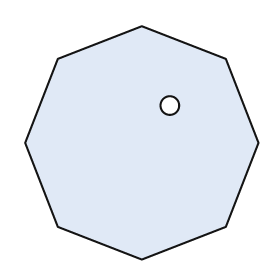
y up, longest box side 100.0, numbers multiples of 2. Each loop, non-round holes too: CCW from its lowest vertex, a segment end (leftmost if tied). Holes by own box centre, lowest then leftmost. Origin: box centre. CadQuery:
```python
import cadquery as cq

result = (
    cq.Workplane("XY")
    .moveTo(0.0, -50.0)
    .lineTo(36.0, -36.0)
    .lineTo(50.0, 0.0)
    .lineTo(36.0, 36.0)
    .lineTo(0.0, 50.0)
    .lineTo(-36.0, 36.0)
    .lineTo(-50.0, 0.0)
    .lineTo(-36.0, -36.0)
    .close()
    .moveTo(12.0, 16.0)
    .circle(4.0)
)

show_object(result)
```